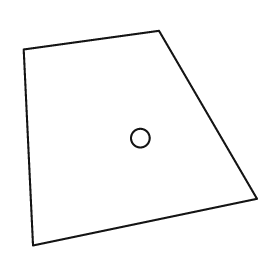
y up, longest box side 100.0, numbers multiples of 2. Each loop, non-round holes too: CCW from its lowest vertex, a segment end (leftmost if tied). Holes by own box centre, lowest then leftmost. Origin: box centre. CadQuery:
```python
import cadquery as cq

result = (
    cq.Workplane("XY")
    .moveTo(-46.0, -46.0)
    .lineTo(50.0, -26.0)
    .lineTo(8.0, 46.0)
    .lineTo(-50.0, 38.0)
    .close()
    .moveTo(0.0, 0.0)
    .circle(4.0)
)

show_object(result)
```